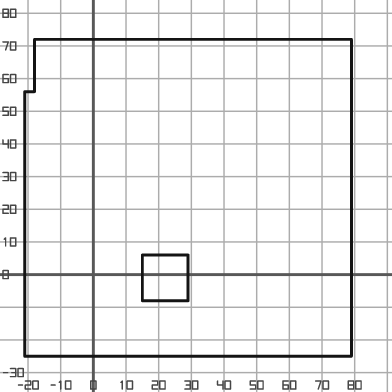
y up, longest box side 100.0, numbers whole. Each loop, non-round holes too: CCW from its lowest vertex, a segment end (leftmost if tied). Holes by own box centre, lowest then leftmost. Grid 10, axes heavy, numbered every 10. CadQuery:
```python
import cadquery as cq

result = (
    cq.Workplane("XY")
    .moveTo(-21.0, -25.0)
    .lineTo(79.0, -25.0)
    .lineTo(79.0, 72.0)
    .lineTo(-18.0, 72.0)
    .lineTo(-18.0, 56.0)
    .lineTo(-21.0, 56.0)
    .close()
    .moveTo(15.0, -8.0)
    .lineTo(29.0, -8.0)
    .lineTo(29.0, 6.0)
    .lineTo(15.0, 6.0)
    .close()
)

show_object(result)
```